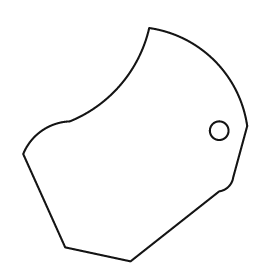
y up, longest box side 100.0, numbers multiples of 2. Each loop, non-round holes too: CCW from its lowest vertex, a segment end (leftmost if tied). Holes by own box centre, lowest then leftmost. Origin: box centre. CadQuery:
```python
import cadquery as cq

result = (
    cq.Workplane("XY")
    .moveTo(-2.0, -50.0)
    .lineTo(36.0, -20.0)
    .threePointArc((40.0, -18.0), (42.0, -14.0))
    .lineTo(48.0, 8.0)
    .threePointArc((34.0, 36.0), (6.0, 50.0))
    .threePointArc((-6.0, 26.0), (-28.0, 10.0))
    .threePointArc((-40.0, 6.0), (-48.0, -4.0))
    .lineTo(-30.0, -44.0)
    .close()
    .moveTo(36.0, 6.0)
    .circle(4.0)
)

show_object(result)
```